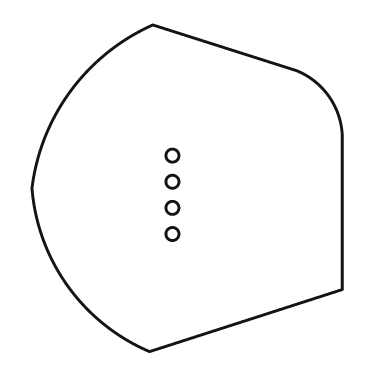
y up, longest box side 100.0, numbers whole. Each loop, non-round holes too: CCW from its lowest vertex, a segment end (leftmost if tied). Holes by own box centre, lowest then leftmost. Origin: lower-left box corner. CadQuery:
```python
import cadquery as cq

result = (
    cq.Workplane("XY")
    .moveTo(36.0, 0.0)
    .lineTo(95.0, 19.0)
    .lineTo(95.0, 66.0)
    .threePointArc((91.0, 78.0), (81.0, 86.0))
    .lineTo(37.0, 100.0)
    .threePointArc((12.0, 80.0), (0.0, 50.0))
    .threePointArc((11.0, 20.0), (36.0, 0.0))
    .close()
    .moveTo(43.0, 36.0)
    .circle(2.0)
    .moveTo(43.0, 44.0)
    .circle(2.0)
    .moveTo(43.0, 52.0)
    .circle(2.0)
    .moveTo(43.0, 60.0)
    .circle(2.0)
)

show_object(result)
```